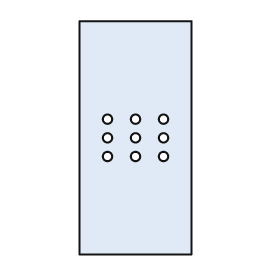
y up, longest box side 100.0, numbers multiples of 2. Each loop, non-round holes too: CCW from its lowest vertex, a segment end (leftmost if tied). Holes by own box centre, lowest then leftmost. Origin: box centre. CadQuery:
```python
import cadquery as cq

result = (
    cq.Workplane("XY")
    .moveTo(-24.0, -50.0)
    .lineTo(24.0, -50.0)
    .lineTo(24.0, 50.0)
    .lineTo(-24.0, 50.0)
    .close()
    .moveTo(-12.0, -8.0)
    .circle(2.0)
    .moveTo(0.0, -8.0)
    .circle(2.0)
    .moveTo(12.0, -8.0)
    .circle(2.0)
    .moveTo(-12.0, 0.0)
    .circle(2.0)
    .moveTo(0.0, 0.0)
    .circle(2.0)
    .moveTo(12.0, 0.0)
    .circle(2.0)
    .moveTo(-12.0, 8.0)
    .circle(2.0)
    .moveTo(0.0, 8.0)
    .circle(2.0)
    .moveTo(12.0, 8.0)
    .circle(2.0)
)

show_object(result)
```